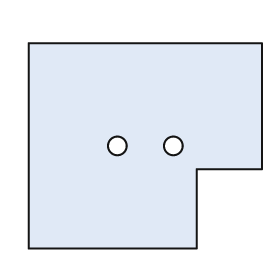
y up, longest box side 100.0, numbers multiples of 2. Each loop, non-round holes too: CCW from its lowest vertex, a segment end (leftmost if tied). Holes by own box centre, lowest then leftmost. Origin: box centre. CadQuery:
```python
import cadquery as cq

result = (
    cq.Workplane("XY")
    .moveTo(-50.0, -44.0)
    .lineTo(22.0, -44.0)
    .lineTo(22.0, -10.0)
    .lineTo(50.0, -10.0)
    .lineTo(50.0, 44.0)
    .lineTo(-50.0, 44.0)
    .close()
    .moveTo(-12.0, 0.0)
    .circle(4.0)
    .moveTo(12.0, 0.0)
    .circle(4.0)
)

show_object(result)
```